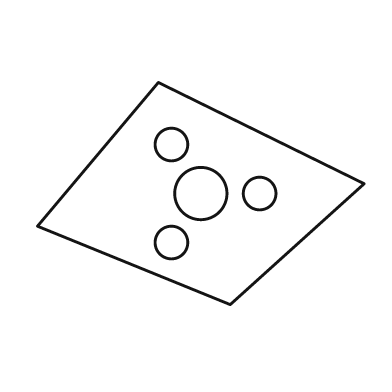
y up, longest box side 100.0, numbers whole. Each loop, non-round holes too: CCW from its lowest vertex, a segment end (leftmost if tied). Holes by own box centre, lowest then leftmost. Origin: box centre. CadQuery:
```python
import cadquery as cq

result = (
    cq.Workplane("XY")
    .moveTo(9.0, -34.0)
    .lineTo(50.0, 3.0)
    .lineTo(-13.0, 34.0)
    .lineTo(-50.0, -10.0)
    .close()
    .moveTo(-9.0, -15.0)
    .circle(5.0)
    .moveTo(0.0, 0.0)
    .circle(8.0)
    .moveTo(18.0, 0.0)
    .circle(5.0)
    .moveTo(-9.0, 15.0)
    .circle(5.0)
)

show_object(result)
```